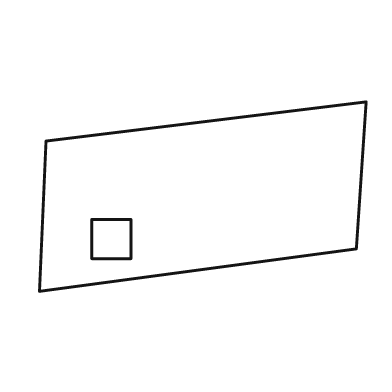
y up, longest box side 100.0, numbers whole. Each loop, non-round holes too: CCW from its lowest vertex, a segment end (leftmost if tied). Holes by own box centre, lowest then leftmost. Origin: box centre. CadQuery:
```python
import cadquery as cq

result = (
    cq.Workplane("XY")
    .moveTo(-50.0, -29.0)
    .lineTo(47.0, -16.0)
    .lineTo(50.0, 29.0)
    .lineTo(-48.0, 17.0)
    .close()
    .moveTo(-34.0, -19.0)
    .lineTo(-22.0, -19.0)
    .lineTo(-22.0, -7.0)
    .lineTo(-34.0, -7.0)
    .close()
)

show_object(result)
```